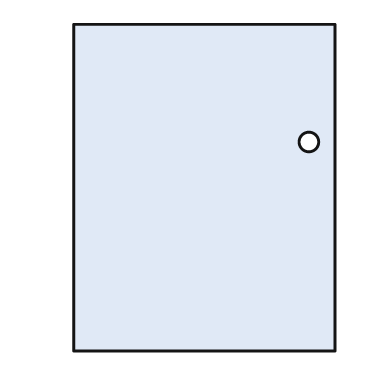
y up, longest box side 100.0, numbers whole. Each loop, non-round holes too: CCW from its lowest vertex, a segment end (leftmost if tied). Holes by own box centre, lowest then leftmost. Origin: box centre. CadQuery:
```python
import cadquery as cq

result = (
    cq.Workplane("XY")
    .moveTo(-40.0, -50.0)
    .lineTo(40.0, -50.0)
    .lineTo(40.0, 50.0)
    .lineTo(-40.0, 50.0)
    .close()
    .moveTo(32.0, 14.0)
    .circle(3.0)
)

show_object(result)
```